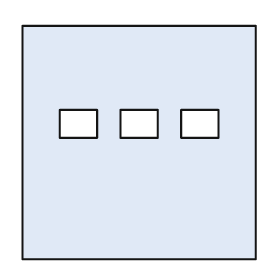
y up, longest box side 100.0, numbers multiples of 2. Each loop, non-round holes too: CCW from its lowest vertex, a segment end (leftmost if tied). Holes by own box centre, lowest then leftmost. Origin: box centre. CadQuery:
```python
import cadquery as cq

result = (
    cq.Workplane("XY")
    .moveTo(-50.0, -50.0)
    .lineTo(50.0, -50.0)
    .lineTo(50.0, 50.0)
    .lineTo(-50.0, 50.0)
    .close()
    .moveTo(-34.0, 2.0)
    .lineTo(-18.0, 2.0)
    .lineTo(-18.0, 14.0)
    .lineTo(-34.0, 14.0)
    .close()
    .moveTo(-8.0, 2.0)
    .lineTo(8.0, 2.0)
    .lineTo(8.0, 14.0)
    .lineTo(-8.0, 14.0)
    .close()
    .moveTo(18.0, 2.0)
    .lineTo(34.0, 2.0)
    .lineTo(34.0, 14.0)
    .lineTo(18.0, 14.0)
    .close()
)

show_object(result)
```